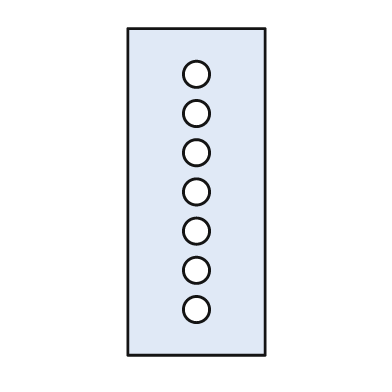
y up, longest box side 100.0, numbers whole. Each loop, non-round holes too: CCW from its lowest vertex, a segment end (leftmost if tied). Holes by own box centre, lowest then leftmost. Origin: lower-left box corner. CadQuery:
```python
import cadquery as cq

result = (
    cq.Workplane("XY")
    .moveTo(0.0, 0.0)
    .lineTo(42.0, 0.0)
    .lineTo(42.0, 100.0)
    .lineTo(0.0, 100.0)
    .close()
    .moveTo(21.0, 14.0)
    .circle(4.0)
    .moveTo(21.0, 26.0)
    .circle(4.0)
    .moveTo(21.0, 38.0)
    .circle(4.0)
    .moveTo(21.0, 50.0)
    .circle(4.0)
    .moveTo(21.0, 62.0)
    .circle(4.0)
    .moveTo(21.0, 74.0)
    .circle(4.0)
    .moveTo(21.0, 86.0)
    .circle(4.0)
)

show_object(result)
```